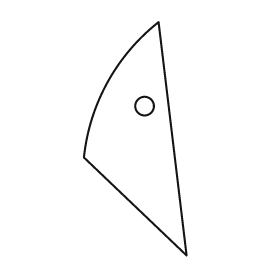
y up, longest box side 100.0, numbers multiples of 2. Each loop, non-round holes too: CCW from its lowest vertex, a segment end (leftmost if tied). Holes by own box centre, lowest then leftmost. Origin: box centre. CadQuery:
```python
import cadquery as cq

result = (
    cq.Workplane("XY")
    .moveTo(22.0, -50.0)
    .lineTo(10.0, 50.0)
    .threePointArc((-12.0, 24.0), (-22.0, -8.0))
    .close()
    .moveTo(4.0, 14.0)
    .circle(4.0)
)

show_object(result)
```